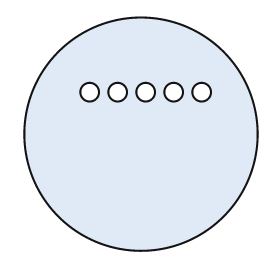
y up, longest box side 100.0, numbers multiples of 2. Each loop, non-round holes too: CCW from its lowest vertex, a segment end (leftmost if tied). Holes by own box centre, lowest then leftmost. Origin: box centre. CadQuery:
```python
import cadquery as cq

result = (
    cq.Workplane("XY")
    .moveTo(0.0, 0.0)
    .circle(50.0)
    .moveTo(-22.0, 18.0)
    .circle(4.0)
    .moveTo(-10.0, 18.0)
    .circle(4.0)
    .moveTo(2.0, 18.0)
    .circle(4.0)
    .moveTo(14.0, 18.0)
    .circle(4.0)
    .moveTo(26.0, 18.0)
    .circle(4.0)
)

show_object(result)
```